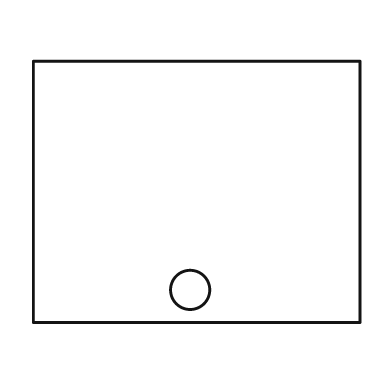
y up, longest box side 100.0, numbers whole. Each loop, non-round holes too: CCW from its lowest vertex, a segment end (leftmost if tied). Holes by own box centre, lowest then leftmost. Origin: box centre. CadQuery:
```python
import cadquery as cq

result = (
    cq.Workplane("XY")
    .moveTo(-50.0, -40.0)
    .lineTo(50.0, -40.0)
    .lineTo(50.0, 40.0)
    .lineTo(-50.0, 40.0)
    .close()
    .moveTo(-2.0, -30.0)
    .circle(6.0)
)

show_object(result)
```